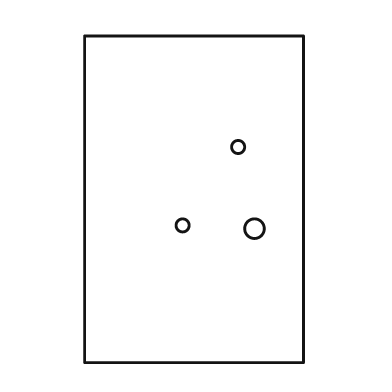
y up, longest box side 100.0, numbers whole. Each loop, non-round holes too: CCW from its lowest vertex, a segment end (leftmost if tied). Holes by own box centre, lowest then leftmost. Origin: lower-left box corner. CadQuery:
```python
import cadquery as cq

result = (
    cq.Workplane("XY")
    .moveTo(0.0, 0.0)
    .lineTo(67.0, 0.0)
    .lineTo(67.0, 100.0)
    .lineTo(0.0, 100.0)
    .close()
    .moveTo(52.0, 41.0)
    .circle(3.0)
    .moveTo(30.0, 42.0)
    .circle(2.0)
    .moveTo(47.0, 66.0)
    .circle(2.0)
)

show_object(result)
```